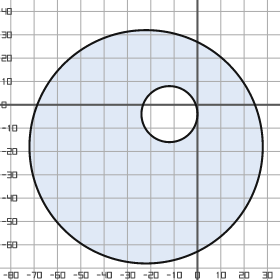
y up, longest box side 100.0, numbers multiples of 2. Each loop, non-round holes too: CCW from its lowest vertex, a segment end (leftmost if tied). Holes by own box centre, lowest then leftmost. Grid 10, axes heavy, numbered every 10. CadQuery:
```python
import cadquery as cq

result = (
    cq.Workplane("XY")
    .moveTo(-22.0, -18.0)
    .circle(50.0)
    .moveTo(-12.0, -4.0)
    .circle(12.0)
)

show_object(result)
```